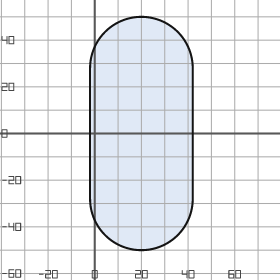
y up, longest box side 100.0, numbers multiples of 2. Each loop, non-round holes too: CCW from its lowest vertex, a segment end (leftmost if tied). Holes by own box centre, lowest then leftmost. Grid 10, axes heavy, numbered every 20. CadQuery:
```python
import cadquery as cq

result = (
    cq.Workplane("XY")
    .moveTo(-2.0, -28.0)
    .threePointArc((20.0, -50.0), (42.0, -28.0))
    .lineTo(42.0, 28.0)
    .threePointArc((20.0, 50.0), (-2.0, 28.0))
    .close()
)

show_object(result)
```